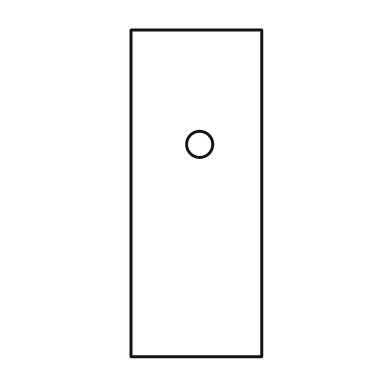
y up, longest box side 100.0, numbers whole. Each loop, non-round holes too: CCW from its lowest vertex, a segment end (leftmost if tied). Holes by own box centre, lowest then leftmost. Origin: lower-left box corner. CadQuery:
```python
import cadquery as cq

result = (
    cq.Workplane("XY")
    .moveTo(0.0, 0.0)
    .lineTo(40.0, 0.0)
    .lineTo(40.0, 100.0)
    .lineTo(0.0, 100.0)
    .close()
    .moveTo(21.0, 65.0)
    .circle(4.0)
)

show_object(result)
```